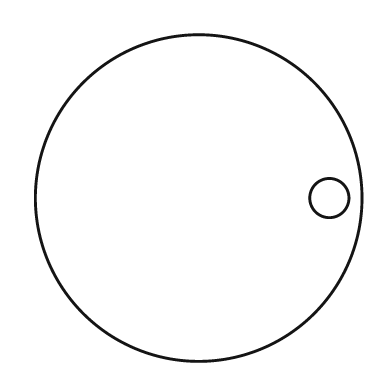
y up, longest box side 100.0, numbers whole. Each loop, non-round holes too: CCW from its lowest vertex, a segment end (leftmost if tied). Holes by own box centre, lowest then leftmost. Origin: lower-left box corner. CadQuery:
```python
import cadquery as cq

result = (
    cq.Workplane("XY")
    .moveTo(50.0, 50.0)
    .circle(50.0)
    .moveTo(90.0, 50.0)
    .circle(6.0)
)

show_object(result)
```